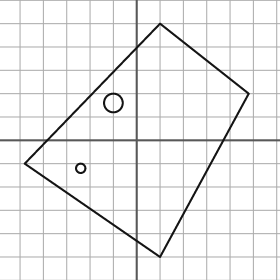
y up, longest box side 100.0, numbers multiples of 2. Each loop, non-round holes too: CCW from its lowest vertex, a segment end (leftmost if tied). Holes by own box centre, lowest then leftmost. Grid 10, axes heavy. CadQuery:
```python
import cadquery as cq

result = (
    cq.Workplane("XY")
    .moveTo(10.0, -50.0)
    .lineTo(48.0, 20.0)
    .lineTo(10.0, 50.0)
    .lineTo(-48.0, -10.0)
    .close()
    .moveTo(-24.0, -12.0)
    .circle(2.0)
    .moveTo(-10.0, 16.0)
    .circle(4.0)
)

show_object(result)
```